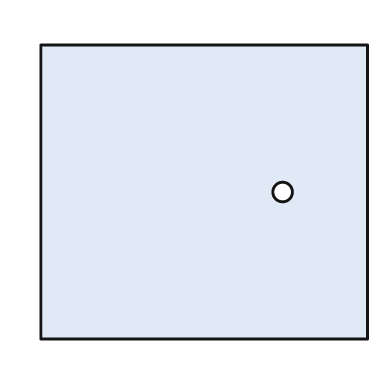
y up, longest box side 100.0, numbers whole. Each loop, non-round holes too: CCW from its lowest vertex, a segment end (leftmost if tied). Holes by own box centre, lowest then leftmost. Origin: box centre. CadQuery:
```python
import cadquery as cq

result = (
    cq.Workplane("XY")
    .moveTo(-50.0, -45.0)
    .lineTo(50.0, -45.0)
    .lineTo(50.0, 45.0)
    .lineTo(-50.0, 45.0)
    .close()
    .moveTo(24.0, 0.0)
    .circle(3.0)
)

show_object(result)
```